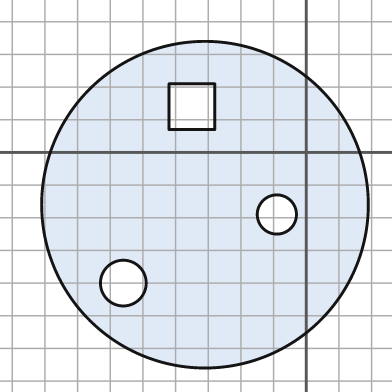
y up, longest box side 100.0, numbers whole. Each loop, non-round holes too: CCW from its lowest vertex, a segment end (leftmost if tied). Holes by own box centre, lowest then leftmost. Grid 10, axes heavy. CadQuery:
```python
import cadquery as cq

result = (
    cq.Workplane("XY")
    .moveTo(-31.0, -16.0)
    .circle(50.0)
    .moveTo(-56.0, -40.0)
    .circle(7.0)
    .moveTo(-9.0, -19.0)
    .circle(6.0)
    .moveTo(-42.0, 7.0)
    .lineTo(-28.0, 7.0)
    .lineTo(-28.0, 21.0)
    .lineTo(-42.0, 21.0)
    .close()
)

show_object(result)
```